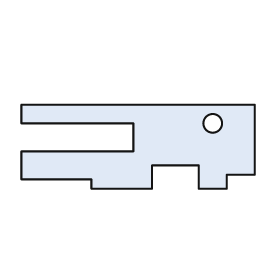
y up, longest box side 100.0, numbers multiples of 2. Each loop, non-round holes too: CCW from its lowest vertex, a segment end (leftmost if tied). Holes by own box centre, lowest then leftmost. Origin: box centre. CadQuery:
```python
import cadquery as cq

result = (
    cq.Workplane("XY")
    .moveTo(-20.0, -18.0)
    .lineTo(6.0, -18.0)
    .lineTo(6.0, -8.0)
    .lineTo(26.0, -8.0)
    .lineTo(26.0, -18.0)
    .lineTo(38.0, -18.0)
    .lineTo(38.0, -12.0)
    .lineTo(50.0, -12.0)
    .lineTo(50.0, 18.0)
    .lineTo(-50.0, 18.0)
    .lineTo(-50.0, 10.0)
    .lineTo(-2.0, 10.0)
    .lineTo(-2.0, -2.0)
    .lineTo(-50.0, -2.0)
    .lineTo(-50.0, -14.0)
    .lineTo(-20.0, -14.0)
    .close()
    .moveTo(32.0, 10.0)
    .circle(4.0)
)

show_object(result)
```